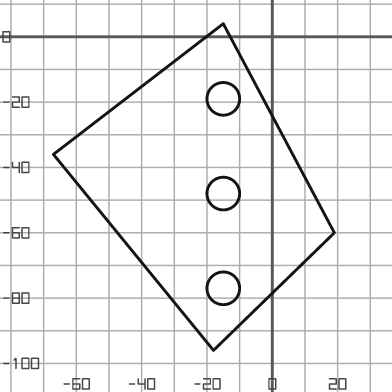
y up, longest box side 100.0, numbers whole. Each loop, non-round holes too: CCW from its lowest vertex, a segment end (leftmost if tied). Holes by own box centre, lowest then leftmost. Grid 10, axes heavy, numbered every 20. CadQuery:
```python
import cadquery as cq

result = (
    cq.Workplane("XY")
    .moveTo(-18.0, -96.0)
    .lineTo(19.0, -60.0)
    .lineTo(-15.0, 4.0)
    .lineTo(-67.0, -36.0)
    .close()
    .moveTo(-15.0, -77.0)
    .circle(5.0)
    .moveTo(-15.0, -48.0)
    .circle(5.0)
    .moveTo(-15.0, -19.0)
    .circle(5.0)
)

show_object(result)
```